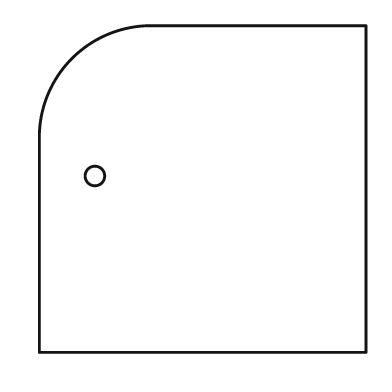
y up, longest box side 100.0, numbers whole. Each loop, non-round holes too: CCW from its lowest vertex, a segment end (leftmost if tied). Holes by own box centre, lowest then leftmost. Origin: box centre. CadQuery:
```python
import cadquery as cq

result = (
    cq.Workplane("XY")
    .moveTo(-50.0, -50.0)
    .lineTo(50.0, -50.0)
    .lineTo(50.0, 50.0)
    .lineTo(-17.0, 50.0)
    .threePointArc((-40.0, 40.0), (-50.0, 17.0))
    .close()
    .moveTo(-33.0, 4.0)
    .circle(3.0)
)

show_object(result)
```